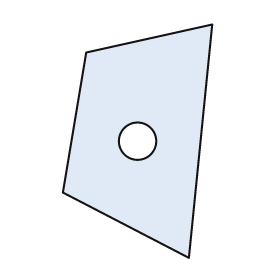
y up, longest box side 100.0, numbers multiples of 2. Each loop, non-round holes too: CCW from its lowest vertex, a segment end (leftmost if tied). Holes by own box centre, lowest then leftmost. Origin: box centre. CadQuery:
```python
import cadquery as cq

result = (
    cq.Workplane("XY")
    .moveTo(22.0, -50.0)
    .lineTo(32.0, 50.0)
    .lineTo(-22.0, 38.0)
    .lineTo(-32.0, -22.0)
    .close()
    .moveTo(0.0, 0.0)
    .circle(8.0)
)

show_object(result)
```